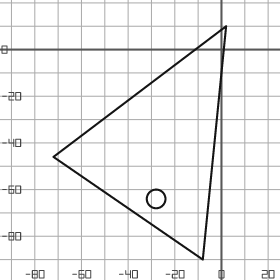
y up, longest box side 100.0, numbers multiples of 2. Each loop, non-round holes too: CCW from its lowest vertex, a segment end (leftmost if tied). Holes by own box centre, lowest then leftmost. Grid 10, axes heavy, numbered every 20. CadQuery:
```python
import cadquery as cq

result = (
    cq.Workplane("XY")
    .moveTo(-8.0, -90.0)
    .lineTo(2.0, 10.0)
    .lineTo(-72.0, -46.0)
    .close()
    .moveTo(-28.0, -64.0)
    .circle(4.0)
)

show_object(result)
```